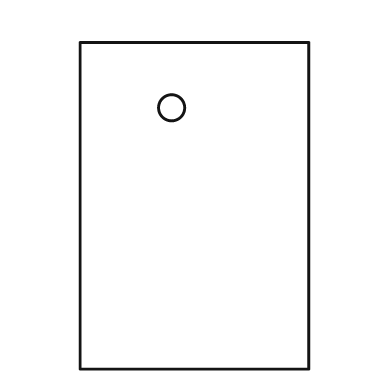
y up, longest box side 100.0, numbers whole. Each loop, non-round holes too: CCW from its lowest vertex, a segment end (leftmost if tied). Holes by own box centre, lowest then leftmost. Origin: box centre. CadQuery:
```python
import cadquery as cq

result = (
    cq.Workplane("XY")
    .moveTo(-35.0, -50.0)
    .lineTo(35.0, -50.0)
    .lineTo(35.0, 50.0)
    .lineTo(-35.0, 50.0)
    .close()
    .moveTo(-7.0, 30.0)
    .circle(4.0)
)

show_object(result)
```